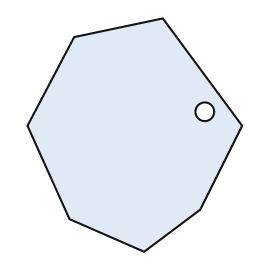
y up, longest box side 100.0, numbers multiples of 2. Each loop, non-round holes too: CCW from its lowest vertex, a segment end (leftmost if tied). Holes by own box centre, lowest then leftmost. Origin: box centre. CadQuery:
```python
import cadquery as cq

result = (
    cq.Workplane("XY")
    .moveTo(4.0, -50.0)
    .lineTo(28.0, -32.0)
    .lineTo(46.0, 4.0)
    .lineTo(12.0, 50.0)
    .lineTo(-26.0, 42.0)
    .lineTo(-46.0, 4.0)
    .lineTo(-28.0, -36.0)
    .close()
    .moveTo(30.0, 10.0)
    .circle(4.0)
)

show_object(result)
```